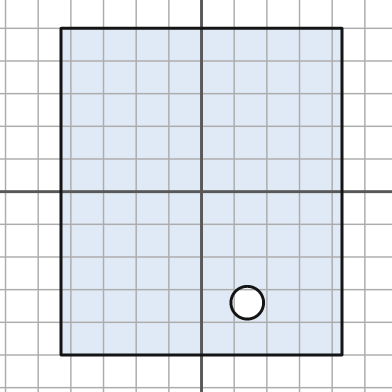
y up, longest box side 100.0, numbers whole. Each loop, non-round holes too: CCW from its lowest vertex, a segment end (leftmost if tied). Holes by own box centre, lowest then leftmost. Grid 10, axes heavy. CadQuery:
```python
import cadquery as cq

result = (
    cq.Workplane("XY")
    .moveTo(-43.0, -50.0)
    .lineTo(43.0, -50.0)
    .lineTo(43.0, 50.0)
    .lineTo(-43.0, 50.0)
    .close()
    .moveTo(14.0, -34.0)
    .circle(5.0)
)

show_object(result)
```